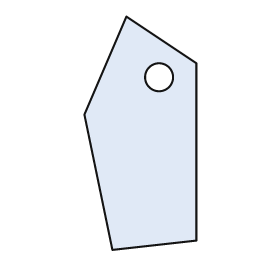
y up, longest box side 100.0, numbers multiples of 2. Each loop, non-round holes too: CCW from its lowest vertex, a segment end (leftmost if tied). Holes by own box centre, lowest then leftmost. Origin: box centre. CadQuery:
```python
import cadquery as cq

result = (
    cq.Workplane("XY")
    .moveTo(-12.0, -50.0)
    .lineTo(24.0, -46.0)
    .lineTo(24.0, 30.0)
    .lineTo(-6.0, 50.0)
    .lineTo(-24.0, 8.0)
    .close()
    .moveTo(8.0, 24.0)
    .circle(6.0)
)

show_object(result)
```